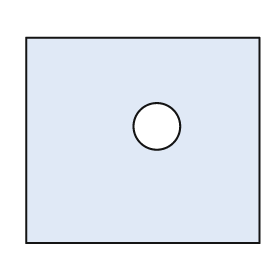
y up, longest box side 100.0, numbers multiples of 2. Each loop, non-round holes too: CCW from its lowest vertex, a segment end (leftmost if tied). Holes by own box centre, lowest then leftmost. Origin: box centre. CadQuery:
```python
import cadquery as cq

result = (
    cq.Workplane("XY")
    .moveTo(-50.0, -44.0)
    .lineTo(50.0, -44.0)
    .lineTo(50.0, 44.0)
    .lineTo(-50.0, 44.0)
    .close()
    .moveTo(6.0, 6.0)
    .circle(10.0)
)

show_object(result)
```